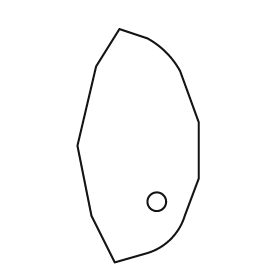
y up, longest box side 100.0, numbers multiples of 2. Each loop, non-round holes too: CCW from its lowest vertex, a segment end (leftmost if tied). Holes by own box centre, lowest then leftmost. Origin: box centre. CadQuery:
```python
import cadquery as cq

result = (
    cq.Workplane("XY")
    .moveTo(-10.0, -50.0)
    .lineTo(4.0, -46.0)
    .threePointArc((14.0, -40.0), (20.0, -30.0))
    .lineTo(26.0, -14.0)
    .lineTo(26.0, 10.0)
    .lineTo(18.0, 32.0)
    .threePointArc((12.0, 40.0), (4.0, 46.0))
    .lineTo(-8.0, 50.0)
    .lineTo(-18.0, 34.0)
    .lineTo(-26.0, 0.0)
    .lineTo(-20.0, -30.0)
    .close()
    .moveTo(8.0, -24.0)
    .circle(4.0)
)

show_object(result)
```